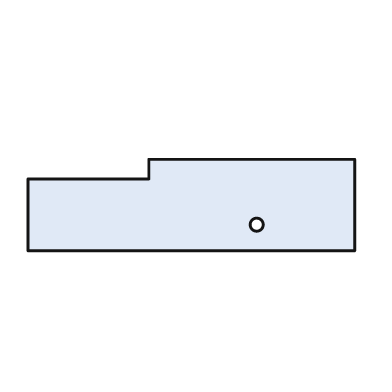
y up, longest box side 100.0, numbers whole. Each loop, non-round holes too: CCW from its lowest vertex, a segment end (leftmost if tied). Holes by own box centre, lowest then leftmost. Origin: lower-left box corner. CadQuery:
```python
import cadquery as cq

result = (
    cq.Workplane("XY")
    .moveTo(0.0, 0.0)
    .lineTo(100.0, 0.0)
    .lineTo(100.0, 28.0)
    .lineTo(37.0, 28.0)
    .lineTo(37.0, 22.0)
    .lineTo(0.0, 22.0)
    .close()
    .moveTo(70.0, 8.0)
    .circle(2.0)
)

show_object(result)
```